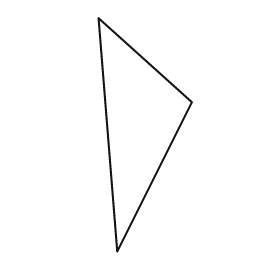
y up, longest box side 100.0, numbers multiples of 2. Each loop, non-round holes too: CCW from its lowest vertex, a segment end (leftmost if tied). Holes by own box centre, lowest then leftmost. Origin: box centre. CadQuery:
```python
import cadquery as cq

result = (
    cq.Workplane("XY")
    .moveTo(-12.0, -50.0)
    .lineTo(20.0, 14.0)
    .lineTo(-20.0, 50.0)
    .close()
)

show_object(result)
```